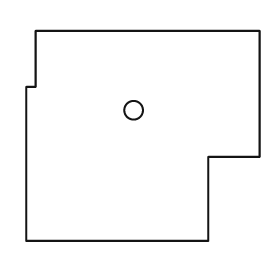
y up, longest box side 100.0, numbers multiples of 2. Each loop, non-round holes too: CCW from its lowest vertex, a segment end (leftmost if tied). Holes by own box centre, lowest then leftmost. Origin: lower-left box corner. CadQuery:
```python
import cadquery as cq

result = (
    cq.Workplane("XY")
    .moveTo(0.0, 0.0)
    .lineTo(78.0, 0.0)
    .lineTo(78.0, 36.0)
    .lineTo(100.0, 36.0)
    .lineTo(100.0, 90.0)
    .lineTo(4.0, 90.0)
    .lineTo(4.0, 66.0)
    .lineTo(0.0, 66.0)
    .close()
    .moveTo(46.0, 56.0)
    .circle(4.0)
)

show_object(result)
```